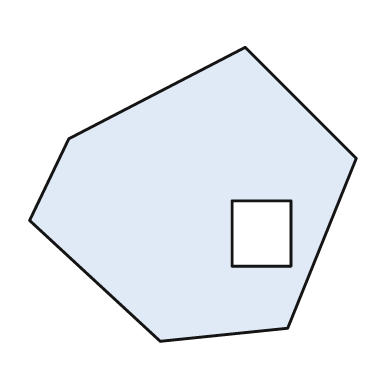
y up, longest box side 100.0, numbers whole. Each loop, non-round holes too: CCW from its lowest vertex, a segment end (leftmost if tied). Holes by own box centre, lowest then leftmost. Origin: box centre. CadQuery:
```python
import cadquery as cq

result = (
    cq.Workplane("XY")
    .moveTo(-10.0, -45.0)
    .lineTo(29.0, -41.0)
    .lineTo(50.0, 11.0)
    .lineTo(16.0, 45.0)
    .lineTo(-38.0, 17.0)
    .lineTo(-50.0, -8.0)
    .close()
    .moveTo(12.0, -22.0)
    .lineTo(30.0, -22.0)
    .lineTo(30.0, -2.0)
    .lineTo(12.0, -2.0)
    .close()
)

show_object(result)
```